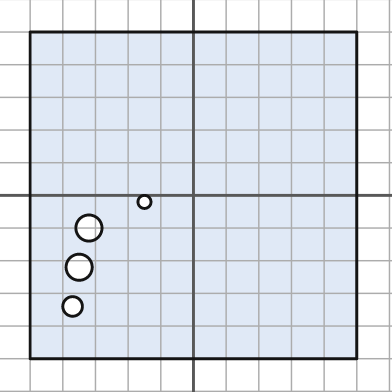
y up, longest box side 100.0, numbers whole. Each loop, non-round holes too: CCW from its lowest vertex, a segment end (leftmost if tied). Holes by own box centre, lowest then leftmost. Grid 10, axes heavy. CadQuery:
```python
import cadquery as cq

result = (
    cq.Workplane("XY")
    .moveTo(-50.0, -50.0)
    .lineTo(50.0, -50.0)
    .lineTo(50.0, 50.0)
    .lineTo(-50.0, 50.0)
    .close()
    .moveTo(-37.0, -34.0)
    .circle(3.0)
    .moveTo(-35.0, -22.0)
    .circle(4.0)
    .moveTo(-32.0, -10.0)
    .circle(4.0)
    .moveTo(-15.0, -2.0)
    .circle(2.0)
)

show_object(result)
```